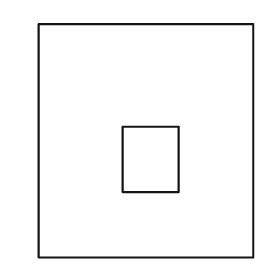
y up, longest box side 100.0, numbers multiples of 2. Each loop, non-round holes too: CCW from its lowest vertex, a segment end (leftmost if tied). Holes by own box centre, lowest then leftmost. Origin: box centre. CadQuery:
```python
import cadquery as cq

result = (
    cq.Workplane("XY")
    .moveTo(-46.0, -50.0)
    .lineTo(46.0, -50.0)
    .lineTo(46.0, 50.0)
    .lineTo(-46.0, 50.0)
    .close()
    .moveTo(-10.0, -22.0)
    .lineTo(14.0, -22.0)
    .lineTo(14.0, 6.0)
    .lineTo(-10.0, 6.0)
    .close()
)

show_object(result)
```